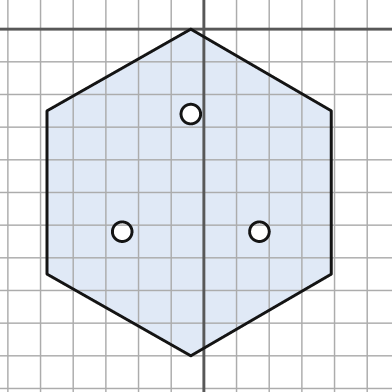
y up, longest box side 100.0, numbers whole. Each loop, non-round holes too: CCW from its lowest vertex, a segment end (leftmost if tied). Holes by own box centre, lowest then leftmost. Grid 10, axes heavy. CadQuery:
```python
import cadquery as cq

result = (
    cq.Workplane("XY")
    .moveTo(-4.0, -100.0)
    .lineTo(39.0, -75.0)
    .lineTo(39.0, -25.0)
    .lineTo(-4.0, 0.0)
    .lineTo(-48.0, -25.0)
    .lineTo(-48.0, -75.0)
    .close()
    .moveTo(-25.0, -62.0)
    .circle(3.0)
    .moveTo(17.0, -62.0)
    .circle(3.0)
    .moveTo(-4.0, -26.0)
    .circle(3.0)
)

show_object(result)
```